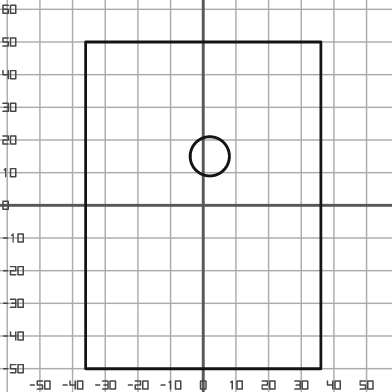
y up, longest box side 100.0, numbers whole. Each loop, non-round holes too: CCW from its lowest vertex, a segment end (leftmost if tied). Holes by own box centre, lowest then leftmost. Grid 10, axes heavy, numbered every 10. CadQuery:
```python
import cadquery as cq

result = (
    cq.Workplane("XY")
    .moveTo(-36.0, -50.0)
    .lineTo(36.0, -50.0)
    .lineTo(36.0, 50.0)
    .lineTo(-36.0, 50.0)
    .close()
    .moveTo(2.0, 15.0)
    .circle(6.0)
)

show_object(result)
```